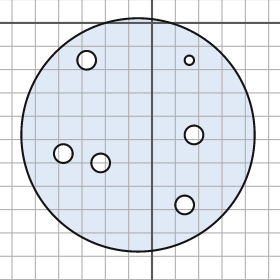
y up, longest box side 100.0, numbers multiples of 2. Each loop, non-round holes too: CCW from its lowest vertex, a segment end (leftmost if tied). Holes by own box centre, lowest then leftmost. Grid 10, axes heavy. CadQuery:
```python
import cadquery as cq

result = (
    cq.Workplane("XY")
    .moveTo(-6.0, -48.0)
    .circle(50.0)
    .moveTo(14.0, -78.0)
    .circle(4.0)
    .moveTo(-22.0, -60.0)
    .circle(4.0)
    .moveTo(-38.0, -56.0)
    .circle(4.0)
    .moveTo(18.0, -48.0)
    .circle(4.0)
    .moveTo(-28.0, -16.0)
    .circle(4.0)
    .moveTo(16.0, -16.0)
    .circle(2.0)
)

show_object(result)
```